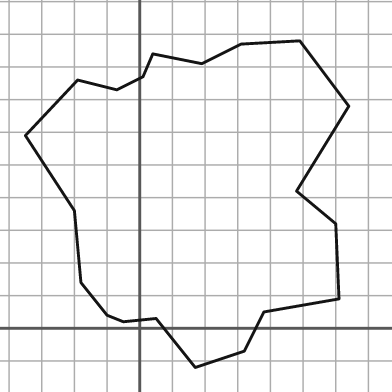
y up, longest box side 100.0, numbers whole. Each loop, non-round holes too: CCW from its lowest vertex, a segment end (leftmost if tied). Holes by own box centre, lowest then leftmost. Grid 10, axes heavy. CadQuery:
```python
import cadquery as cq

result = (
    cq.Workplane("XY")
    .moveTo(17.0, -12.0)
    .lineTo(32.0, -7.0)
    .lineTo(38.0, 5.0)
    .lineTo(61.0, 9.0)
    .lineTo(60.0, 32.0)
    .lineTo(48.0, 42.0)
    .lineTo(64.0, 68.0)
    .lineTo(49.0, 88.0)
    .lineTo(31.0, 87.0)
    .lineTo(19.0, 81.0)
    .lineTo(4.0, 84.0)
    .lineTo(1.0, 77.0)
    .lineTo(-7.0, 73.0)
    .lineTo(-19.0, 76.0)
    .lineTo(-35.0, 59.0)
    .lineTo(-20.0, 36.0)
    .lineTo(-18.0, 14.0)
    .lineTo(-10.0, 4.0)
    .lineTo(-5.0, 2.0)
    .lineTo(5.0, 3.0)
    .close()
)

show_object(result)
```